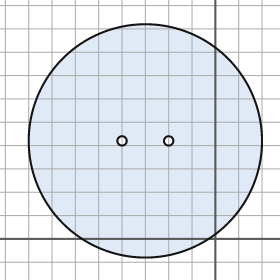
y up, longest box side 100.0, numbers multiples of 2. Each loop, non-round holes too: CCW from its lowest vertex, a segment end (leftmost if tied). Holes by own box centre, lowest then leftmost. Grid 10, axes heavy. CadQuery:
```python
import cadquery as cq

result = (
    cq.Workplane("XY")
    .moveTo(-30.0, 42.0)
    .circle(50.0)
    .moveTo(-40.0, 42.0)
    .circle(2.0)
    .moveTo(-20.0, 42.0)
    .circle(2.0)
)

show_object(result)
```